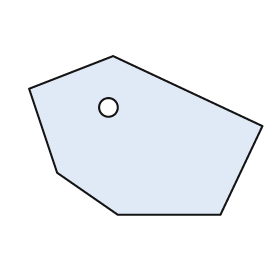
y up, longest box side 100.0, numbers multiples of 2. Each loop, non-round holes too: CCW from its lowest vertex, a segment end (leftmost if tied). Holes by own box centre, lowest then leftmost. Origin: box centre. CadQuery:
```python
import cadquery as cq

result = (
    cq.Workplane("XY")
    .moveTo(-12.0, -34.0)
    .lineTo(32.0, -34.0)
    .lineTo(50.0, 4.0)
    .lineTo(-14.0, 34.0)
    .lineTo(-50.0, 20.0)
    .lineTo(-38.0, -16.0)
    .close()
    .moveTo(-16.0, 12.0)
    .circle(4.0)
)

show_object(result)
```